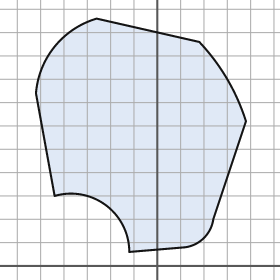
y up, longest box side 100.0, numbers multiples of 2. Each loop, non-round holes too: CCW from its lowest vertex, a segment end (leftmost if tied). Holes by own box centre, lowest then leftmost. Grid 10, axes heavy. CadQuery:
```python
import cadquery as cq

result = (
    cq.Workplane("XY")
    .moveTo(-12.0, 6.0)
    .lineTo(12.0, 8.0)
    .threePointArc((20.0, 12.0), (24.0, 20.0))
    .lineTo(38.0, 62.0)
    .threePointArc((30.0, 80.0), (18.0, 96.0))
    .lineTo(-26.0, 106.0)
    .threePointArc((-44.0, 94.0), (-52.0, 74.0))
    .lineTo(-44.0, 30.0)
    .threePointArc((-22.0, 26.0), (-12.0, 6.0))
    .close()
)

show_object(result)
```